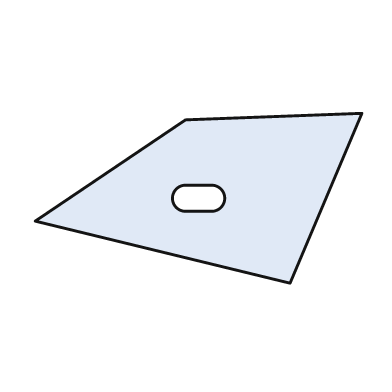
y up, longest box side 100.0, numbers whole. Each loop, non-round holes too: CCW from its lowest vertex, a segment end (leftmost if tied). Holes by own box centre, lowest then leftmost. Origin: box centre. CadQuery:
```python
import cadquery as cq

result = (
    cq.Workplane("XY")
    .moveTo(28.0, -26.0)
    .lineTo(50.0, 26.0)
    .lineTo(-4.0, 24.0)
    .lineTo(-50.0, -7.0)
    .close()
    .moveTo(-4.0, -4.0)
    .lineTo(4.0, -4.0)
    .threePointArc((8.0, 0.0), (4.0, 4.0))
    .lineTo(-4.0, 4.0)
    .threePointArc((-8.0, 0.0), (-4.0, -4.0))
    .close()
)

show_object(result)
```